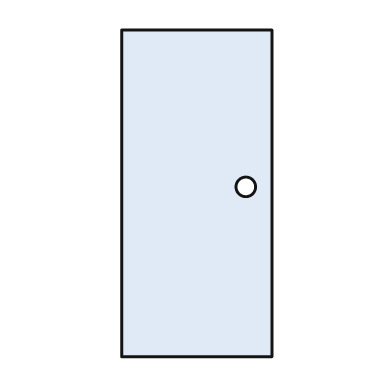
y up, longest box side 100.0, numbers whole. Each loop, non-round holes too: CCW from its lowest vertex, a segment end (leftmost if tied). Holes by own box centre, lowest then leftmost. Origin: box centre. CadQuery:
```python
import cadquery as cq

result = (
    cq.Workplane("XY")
    .moveTo(-23.0, -50.0)
    .lineTo(23.0, -50.0)
    .lineTo(23.0, 50.0)
    .lineTo(-23.0, 50.0)
    .close()
    .moveTo(15.0, 2.0)
    .circle(3.0)
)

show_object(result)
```